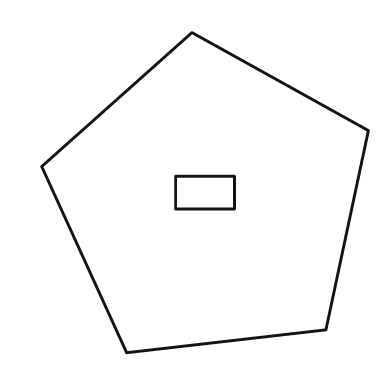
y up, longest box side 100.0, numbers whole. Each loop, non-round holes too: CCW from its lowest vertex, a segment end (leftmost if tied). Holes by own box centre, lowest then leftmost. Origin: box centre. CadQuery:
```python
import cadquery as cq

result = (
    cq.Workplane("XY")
    .moveTo(-24.0, -49.0)
    .lineTo(37.0, -42.0)
    .lineTo(50.0, 19.0)
    .lineTo(-4.0, 49.0)
    .lineTo(-50.0, 8.0)
    .close()
    .moveTo(-9.0, -5.0)
    .lineTo(9.0, -5.0)
    .lineTo(9.0, 5.0)
    .lineTo(-9.0, 5.0)
    .close()
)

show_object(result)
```